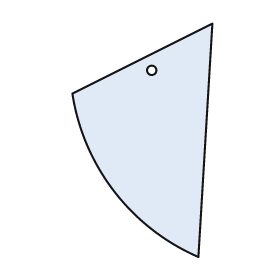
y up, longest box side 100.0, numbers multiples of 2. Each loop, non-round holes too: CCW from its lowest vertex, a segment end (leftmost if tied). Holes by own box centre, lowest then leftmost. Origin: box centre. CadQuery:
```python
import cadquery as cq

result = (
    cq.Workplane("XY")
    .moveTo(24.0, -50.0)
    .lineTo(30.0, 50.0)
    .lineTo(-30.0, 20.0)
    .threePointArc((-12.0, -22.0), (24.0, -50.0))
    .close()
    .moveTo(4.0, 30.0)
    .circle(2.0)
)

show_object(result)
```